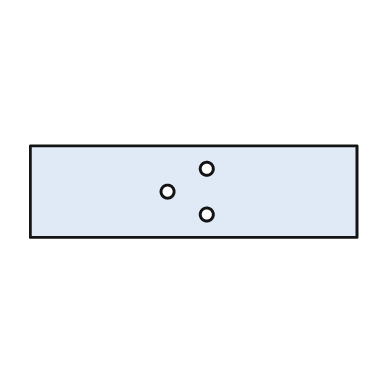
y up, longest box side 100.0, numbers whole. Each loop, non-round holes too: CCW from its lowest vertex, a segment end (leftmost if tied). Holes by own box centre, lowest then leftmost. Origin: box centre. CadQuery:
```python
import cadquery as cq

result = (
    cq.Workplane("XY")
    .moveTo(-50.0, -14.0)
    .lineTo(50.0, -14.0)
    .lineTo(50.0, 14.0)
    .lineTo(-50.0, 14.0)
    .close()
    .moveTo(4.0, -7.0)
    .circle(2.0)
    .moveTo(-8.0, 0.0)
    .circle(2.0)
    .moveTo(4.0, 7.0)
    .circle(2.0)
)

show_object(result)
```